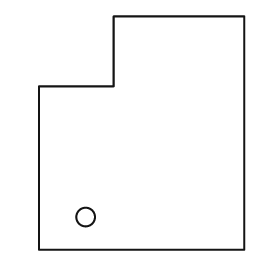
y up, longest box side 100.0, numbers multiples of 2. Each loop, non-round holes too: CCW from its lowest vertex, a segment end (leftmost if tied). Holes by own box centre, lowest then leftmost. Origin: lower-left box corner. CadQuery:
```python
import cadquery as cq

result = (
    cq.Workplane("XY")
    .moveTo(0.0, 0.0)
    .lineTo(88.0, 0.0)
    .lineTo(88.0, 100.0)
    .lineTo(32.0, 100.0)
    .lineTo(32.0, 70.0)
    .lineTo(0.0, 70.0)
    .close()
    .moveTo(20.0, 14.0)
    .circle(4.0)
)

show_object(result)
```